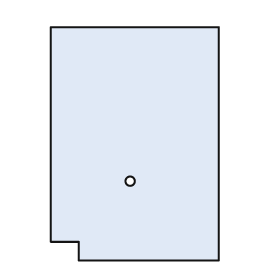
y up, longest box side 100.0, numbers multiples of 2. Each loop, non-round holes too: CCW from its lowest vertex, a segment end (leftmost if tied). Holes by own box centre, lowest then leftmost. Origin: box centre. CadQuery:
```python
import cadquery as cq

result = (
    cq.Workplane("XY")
    .moveTo(-24.0, -50.0)
    .lineTo(36.0, -50.0)
    .lineTo(36.0, 50.0)
    .lineTo(-36.0, 50.0)
    .lineTo(-36.0, -42.0)
    .lineTo(-24.0, -42.0)
    .close()
    .moveTo(-2.0, -16.0)
    .circle(2.0)
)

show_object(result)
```